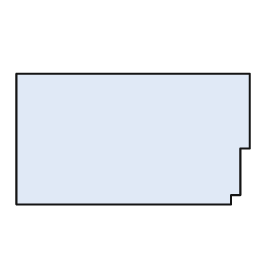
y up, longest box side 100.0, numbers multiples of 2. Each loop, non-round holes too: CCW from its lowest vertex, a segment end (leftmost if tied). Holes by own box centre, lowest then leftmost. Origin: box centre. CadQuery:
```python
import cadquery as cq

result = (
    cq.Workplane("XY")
    .moveTo(-50.0, -28.0)
    .lineTo(42.0, -28.0)
    .lineTo(42.0, -24.0)
    .lineTo(46.0, -24.0)
    .lineTo(46.0, -4.0)
    .lineTo(50.0, -4.0)
    .lineTo(50.0, 28.0)
    .lineTo(-50.0, 28.0)
    .close()
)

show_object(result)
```